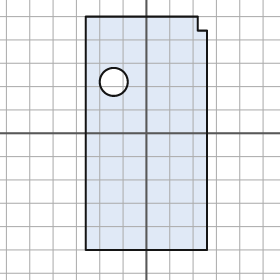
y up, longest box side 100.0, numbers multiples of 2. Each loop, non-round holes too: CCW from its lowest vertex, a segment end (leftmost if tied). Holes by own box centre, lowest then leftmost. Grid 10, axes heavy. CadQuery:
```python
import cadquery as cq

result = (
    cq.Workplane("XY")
    .moveTo(-26.0, -50.0)
    .lineTo(26.0, -50.0)
    .lineTo(26.0, 44.0)
    .lineTo(22.0, 44.0)
    .lineTo(22.0, 50.0)
    .lineTo(-26.0, 50.0)
    .close()
    .moveTo(-14.0, 22.0)
    .circle(6.0)
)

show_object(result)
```